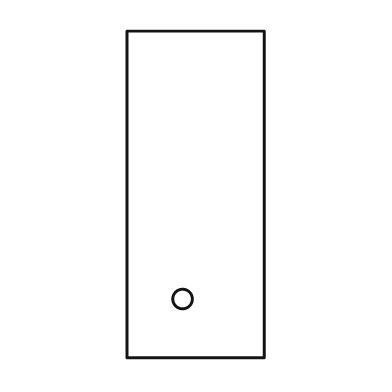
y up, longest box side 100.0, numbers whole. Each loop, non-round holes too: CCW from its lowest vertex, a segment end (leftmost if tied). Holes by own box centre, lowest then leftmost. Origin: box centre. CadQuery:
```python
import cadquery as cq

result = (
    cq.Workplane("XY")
    .moveTo(-21.0, -50.0)
    .lineTo(21.0, -50.0)
    .lineTo(21.0, 50.0)
    .lineTo(-21.0, 50.0)
    .close()
    .moveTo(-4.0, -32.0)
    .circle(3.0)
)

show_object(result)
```